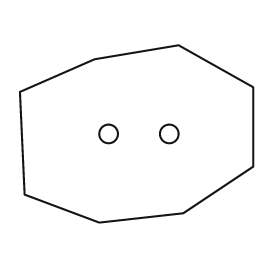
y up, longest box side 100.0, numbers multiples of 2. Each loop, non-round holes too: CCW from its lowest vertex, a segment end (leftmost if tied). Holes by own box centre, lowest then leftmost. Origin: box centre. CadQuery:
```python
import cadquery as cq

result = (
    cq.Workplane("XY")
    .moveTo(-16.0, -38.0)
    .lineTo(20.0, -34.0)
    .lineTo(50.0, -14.0)
    .lineTo(50.0, 20.0)
    .lineTo(18.0, 38.0)
    .lineTo(-18.0, 32.0)
    .lineTo(-50.0, 18.0)
    .lineTo(-48.0, -26.0)
    .close()
    .moveTo(-12.0, 0.0)
    .circle(4.0)
    .moveTo(14.0, 0.0)
    .circle(4.0)
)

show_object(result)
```